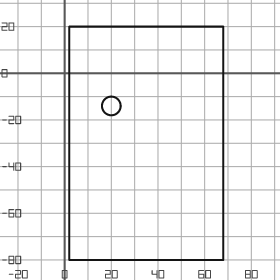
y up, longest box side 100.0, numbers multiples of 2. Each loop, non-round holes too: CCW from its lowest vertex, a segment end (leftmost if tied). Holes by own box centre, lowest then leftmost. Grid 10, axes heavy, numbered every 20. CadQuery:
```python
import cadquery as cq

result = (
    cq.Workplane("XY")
    .moveTo(2.0, -80.0)
    .lineTo(68.0, -80.0)
    .lineTo(68.0, 20.0)
    .lineTo(2.0, 20.0)
    .close()
    .moveTo(20.0, -14.0)
    .circle(4.0)
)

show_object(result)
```